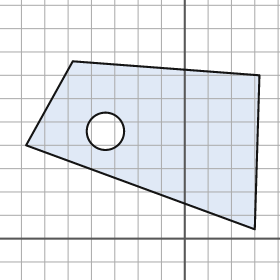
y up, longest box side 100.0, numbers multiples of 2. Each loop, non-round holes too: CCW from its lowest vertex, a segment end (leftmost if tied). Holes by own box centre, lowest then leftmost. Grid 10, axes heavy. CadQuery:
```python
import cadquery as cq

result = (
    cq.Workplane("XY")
    .moveTo(30.0, 4.0)
    .lineTo(32.0, 70.0)
    .lineTo(-48.0, 76.0)
    .lineTo(-68.0, 40.0)
    .close()
    .moveTo(-34.0, 46.0)
    .circle(8.0)
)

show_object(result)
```